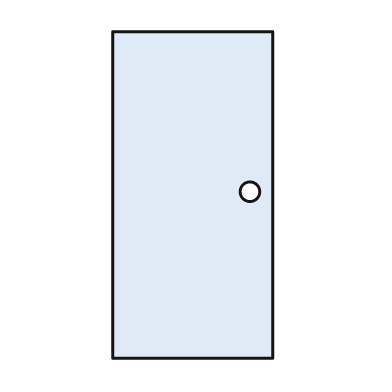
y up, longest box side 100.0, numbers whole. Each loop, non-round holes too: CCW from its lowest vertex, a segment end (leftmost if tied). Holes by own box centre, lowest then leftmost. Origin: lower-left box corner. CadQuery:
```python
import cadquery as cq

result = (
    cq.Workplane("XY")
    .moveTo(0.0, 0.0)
    .lineTo(49.0, 0.0)
    .lineTo(49.0, 100.0)
    .lineTo(0.0, 100.0)
    .close()
    .moveTo(42.0, 51.0)
    .circle(3.0)
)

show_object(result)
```